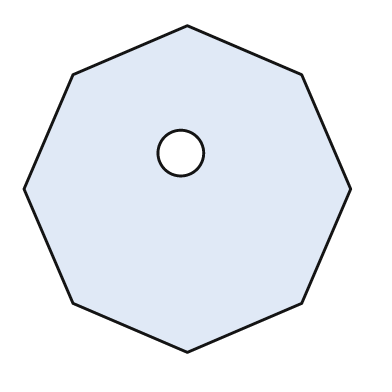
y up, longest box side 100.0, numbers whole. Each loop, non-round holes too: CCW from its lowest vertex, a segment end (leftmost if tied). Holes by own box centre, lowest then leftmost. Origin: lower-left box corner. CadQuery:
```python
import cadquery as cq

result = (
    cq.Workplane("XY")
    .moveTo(50.0, 0.0)
    .lineTo(85.0, 15.0)
    .lineTo(100.0, 50.0)
    .lineTo(85.0, 85.0)
    .lineTo(50.0, 100.0)
    .lineTo(15.0, 85.0)
    .lineTo(0.0, 50.0)
    .lineTo(15.0, 15.0)
    .close()
    .moveTo(48.0, 61.0)
    .circle(7.0)
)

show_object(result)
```